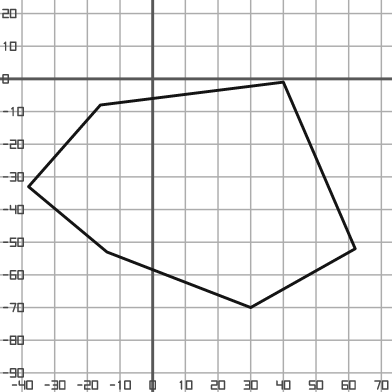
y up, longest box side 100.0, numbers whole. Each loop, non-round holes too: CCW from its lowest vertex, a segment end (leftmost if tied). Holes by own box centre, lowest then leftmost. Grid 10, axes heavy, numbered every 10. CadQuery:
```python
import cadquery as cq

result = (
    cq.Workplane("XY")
    .moveTo(30.0, -70.0)
    .lineTo(62.0, -52.0)
    .lineTo(40.0, -1.0)
    .lineTo(-16.0, -8.0)
    .lineTo(-38.0, -33.0)
    .lineTo(-14.0, -53.0)
    .close()
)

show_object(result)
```